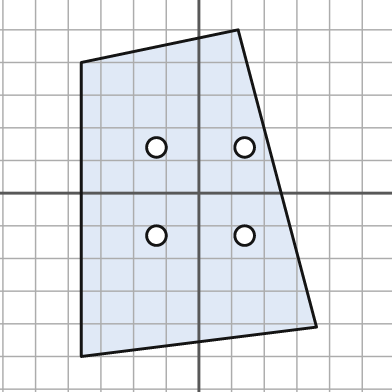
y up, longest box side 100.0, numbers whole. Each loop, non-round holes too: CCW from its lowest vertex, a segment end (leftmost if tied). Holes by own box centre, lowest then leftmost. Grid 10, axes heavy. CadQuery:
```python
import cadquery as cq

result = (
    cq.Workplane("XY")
    .moveTo(-36.0, -50.0)
    .lineTo(36.0, -41.0)
    .lineTo(12.0, 50.0)
    .lineTo(-36.0, 40.0)
    .close()
    .moveTo(-13.0, -13.0)
    .circle(3.0)
    .moveTo(14.0, -13.0)
    .circle(3.0)
    .moveTo(-13.0, 14.0)
    .circle(3.0)
    .moveTo(14.0, 14.0)
    .circle(3.0)
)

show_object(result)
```